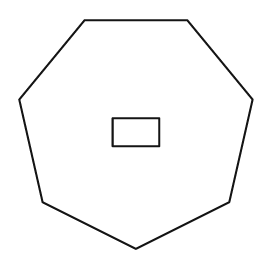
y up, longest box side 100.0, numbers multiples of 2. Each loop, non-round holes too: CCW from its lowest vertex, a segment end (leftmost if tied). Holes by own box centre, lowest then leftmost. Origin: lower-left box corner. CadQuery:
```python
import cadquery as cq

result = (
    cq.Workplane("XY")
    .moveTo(50.0, 0.0)
    .lineTo(90.0, 20.0)
    .lineTo(100.0, 64.0)
    .lineTo(72.0, 98.0)
    .lineTo(28.0, 98.0)
    .lineTo(0.0, 64.0)
    .lineTo(10.0, 20.0)
    .close()
    .moveTo(40.0, 44.0)
    .lineTo(60.0, 44.0)
    .lineTo(60.0, 56.0)
    .lineTo(40.0, 56.0)
    .close()
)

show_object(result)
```